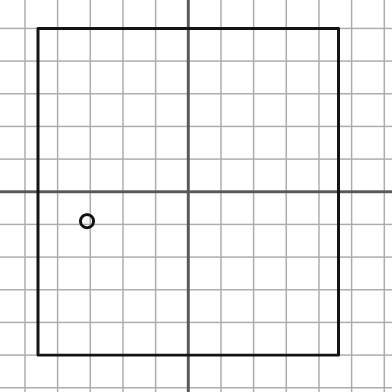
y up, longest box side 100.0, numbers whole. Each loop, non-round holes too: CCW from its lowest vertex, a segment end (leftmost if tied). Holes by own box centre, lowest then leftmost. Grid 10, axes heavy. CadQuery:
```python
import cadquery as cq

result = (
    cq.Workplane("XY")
    .moveTo(-46.0, -50.0)
    .lineTo(46.0, -50.0)
    .lineTo(46.0, 50.0)
    .lineTo(-46.0, 50.0)
    .close()
    .moveTo(-31.0, -9.0)
    .circle(2.0)
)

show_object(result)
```